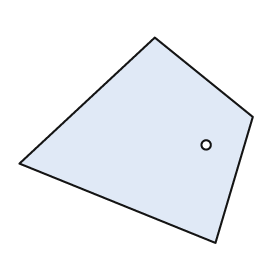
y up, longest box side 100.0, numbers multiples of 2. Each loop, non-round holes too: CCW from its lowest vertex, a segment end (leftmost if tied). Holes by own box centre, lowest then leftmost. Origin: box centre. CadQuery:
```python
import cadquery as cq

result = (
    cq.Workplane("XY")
    .moveTo(34.0, -44.0)
    .lineTo(50.0, 10.0)
    .lineTo(8.0, 44.0)
    .lineTo(-50.0, -10.0)
    .close()
    .moveTo(30.0, -2.0)
    .circle(2.0)
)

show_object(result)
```